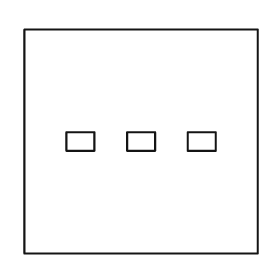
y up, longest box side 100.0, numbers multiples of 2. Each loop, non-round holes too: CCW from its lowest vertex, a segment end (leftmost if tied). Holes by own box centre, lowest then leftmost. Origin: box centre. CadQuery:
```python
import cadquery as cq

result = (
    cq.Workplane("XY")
    .moveTo(-50.0, -48.0)
    .lineTo(50.0, -48.0)
    .lineTo(50.0, 48.0)
    .lineTo(-50.0, 48.0)
    .close()
    .moveTo(-32.0, -4.0)
    .lineTo(-20.0, -4.0)
    .lineTo(-20.0, 4.0)
    .lineTo(-32.0, 4.0)
    .close()
    .moveTo(-6.0, -4.0)
    .lineTo(6.0, -4.0)
    .lineTo(6.0, 4.0)
    .lineTo(-6.0, 4.0)
    .close()
    .moveTo(20.0, -4.0)
    .lineTo(32.0, -4.0)
    .lineTo(32.0, 4.0)
    .lineTo(20.0, 4.0)
    .close()
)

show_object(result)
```